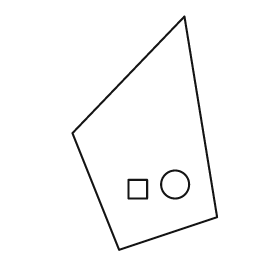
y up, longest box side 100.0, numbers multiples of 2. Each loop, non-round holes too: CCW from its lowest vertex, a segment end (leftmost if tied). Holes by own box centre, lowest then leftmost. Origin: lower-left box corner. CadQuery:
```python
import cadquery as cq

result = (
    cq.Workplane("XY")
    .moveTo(20.0, 0.0)
    .lineTo(62.0, 14.0)
    .lineTo(48.0, 100.0)
    .lineTo(0.0, 50.0)
    .close()
    .moveTo(24.0, 22.0)
    .lineTo(32.0, 22.0)
    .lineTo(32.0, 30.0)
    .lineTo(24.0, 30.0)
    .close()
    .moveTo(44.0, 28.0)
    .circle(6.0)
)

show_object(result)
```